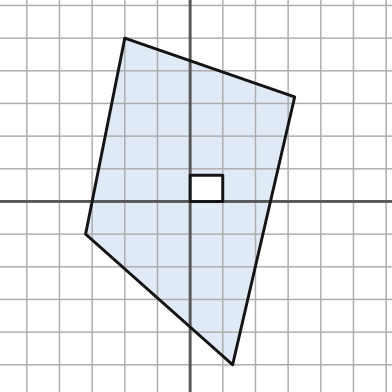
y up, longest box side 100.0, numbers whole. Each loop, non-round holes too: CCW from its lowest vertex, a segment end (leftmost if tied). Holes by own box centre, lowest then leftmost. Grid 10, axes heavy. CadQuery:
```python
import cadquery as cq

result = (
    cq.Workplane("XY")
    .moveTo(13.0, -50.0)
    .lineTo(32.0, 32.0)
    .lineTo(-20.0, 50.0)
    .lineTo(-32.0, -10.0)
    .close()
    .moveTo(0.0, 0.0)
    .lineTo(10.0, 0.0)
    .lineTo(10.0, 8.0)
    .lineTo(0.0, 8.0)
    .close()
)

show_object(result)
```